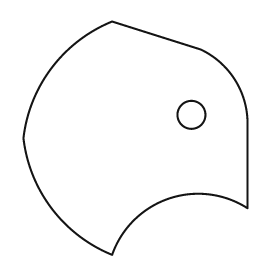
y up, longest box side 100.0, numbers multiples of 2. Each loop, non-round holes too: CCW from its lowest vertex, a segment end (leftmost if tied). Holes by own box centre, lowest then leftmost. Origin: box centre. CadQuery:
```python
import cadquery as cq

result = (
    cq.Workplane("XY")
    .moveTo(-10.0, -50.0)
    .threePointArc((14.0, -26.0), (48.0, -30.0))
    .lineTo(48.0, 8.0)
    .threePointArc((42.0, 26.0), (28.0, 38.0))
    .lineTo(-10.0, 50.0)
    .threePointArc((-36.0, 30.0), (-48.0, 0.0))
    .threePointArc((-36.0, -30.0), (-10.0, -50.0))
    .close()
    .moveTo(24.0, 10.0)
    .circle(6.0)
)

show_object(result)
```